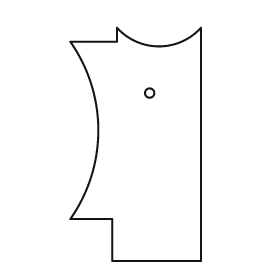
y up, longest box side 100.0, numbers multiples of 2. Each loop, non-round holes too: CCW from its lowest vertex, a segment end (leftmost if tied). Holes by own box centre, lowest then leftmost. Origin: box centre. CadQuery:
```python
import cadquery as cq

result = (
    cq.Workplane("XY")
    .moveTo(-10.0, -50.0)
    .lineTo(28.0, -50.0)
    .lineTo(28.0, 50.0)
    .threePointArc((10.0, 42.0), (-8.0, 50.0))
    .lineTo(-8.0, 44.0)
    .lineTo(-28.0, 44.0)
    .threePointArc((-16.0, 6.0), (-28.0, -32.0))
    .lineTo(-10.0, -32.0)
    .close()
    .moveTo(6.0, 22.0)
    .circle(2.0)
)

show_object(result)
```